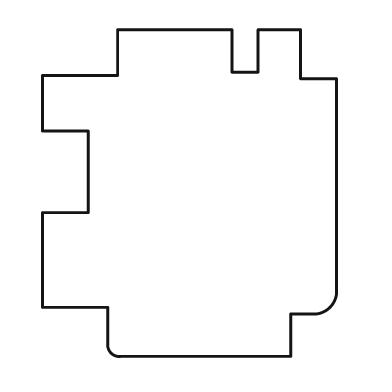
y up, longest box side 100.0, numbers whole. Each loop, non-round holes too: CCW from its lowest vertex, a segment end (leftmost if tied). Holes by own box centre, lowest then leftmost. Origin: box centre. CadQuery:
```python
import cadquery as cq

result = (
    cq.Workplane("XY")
    .moveTo(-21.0, -50.0)
    .lineTo(31.0, -50.0)
    .lineTo(31.0, -37.0)
    .lineTo(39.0, -37.0)
    .threePointArc((43.0, -35.0), (45.0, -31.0))
    .lineTo(45.0, 35.0)
    .lineTo(34.0, 35.0)
    .lineTo(34.0, 50.0)
    .lineTo(21.0, 50.0)
    .lineTo(21.0, 37.0)
    .lineTo(13.0, 37.0)
    .lineTo(13.0, 50.0)
    .lineTo(-22.0, 50.0)
    .lineTo(-22.0, 36.0)
    .lineTo(-45.0, 36.0)
    .lineTo(-45.0, 19.0)
    .lineTo(-31.0, 19.0)
    .lineTo(-31.0, -6.0)
    .lineTo(-45.0, -6.0)
    .lineTo(-45.0, -35.0)
    .lineTo(-25.0, -35.0)
    .lineTo(-25.0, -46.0)
    .threePointArc((-24.0, -49.0), (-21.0, -50.0))
    .close()
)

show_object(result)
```